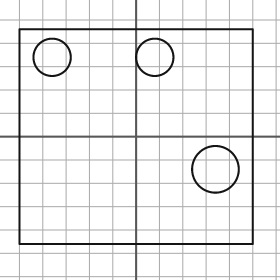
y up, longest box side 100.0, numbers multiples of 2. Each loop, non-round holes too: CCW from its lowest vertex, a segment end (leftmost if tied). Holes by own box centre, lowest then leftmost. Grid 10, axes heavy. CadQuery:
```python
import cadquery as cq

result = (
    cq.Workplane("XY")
    .moveTo(-50.0, -46.0)
    .lineTo(50.0, -46.0)
    .lineTo(50.0, 46.0)
    .lineTo(-50.0, 46.0)
    .close()
    .moveTo(34.0, -14.0)
    .circle(10.0)
    .moveTo(-36.0, 34.0)
    .circle(8.0)
    .moveTo(8.0, 34.0)
    .circle(8.0)
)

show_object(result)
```